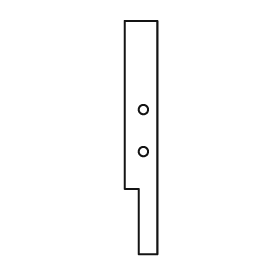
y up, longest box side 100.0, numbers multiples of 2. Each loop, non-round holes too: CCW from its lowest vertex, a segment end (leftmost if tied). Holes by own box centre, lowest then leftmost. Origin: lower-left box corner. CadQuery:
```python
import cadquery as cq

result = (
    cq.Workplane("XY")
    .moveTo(6.0, 0.0)
    .lineTo(14.0, 0.0)
    .lineTo(14.0, 100.0)
    .lineTo(0.0, 100.0)
    .lineTo(0.0, 28.0)
    .lineTo(6.0, 28.0)
    .close()
    .moveTo(8.0, 44.0)
    .circle(2.0)
    .moveTo(8.0, 62.0)
    .circle(2.0)
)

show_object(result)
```